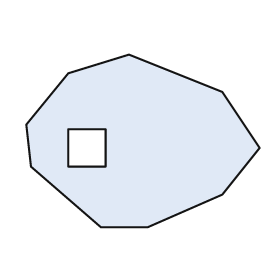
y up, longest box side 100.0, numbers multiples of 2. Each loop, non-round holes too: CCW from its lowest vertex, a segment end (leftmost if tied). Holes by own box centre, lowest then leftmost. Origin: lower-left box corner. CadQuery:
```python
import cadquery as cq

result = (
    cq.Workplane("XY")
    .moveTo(32.0, 0.0)
    .lineTo(52.0, 0.0)
    .lineTo(84.0, 14.0)
    .lineTo(100.0, 34.0)
    .lineTo(84.0, 58.0)
    .lineTo(44.0, 74.0)
    .lineTo(18.0, 66.0)
    .lineTo(0.0, 44.0)
    .lineTo(2.0, 26.0)
    .close()
    .moveTo(18.0, 26.0)
    .lineTo(34.0, 26.0)
    .lineTo(34.0, 42.0)
    .lineTo(18.0, 42.0)
    .close()
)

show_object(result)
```